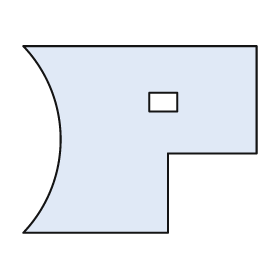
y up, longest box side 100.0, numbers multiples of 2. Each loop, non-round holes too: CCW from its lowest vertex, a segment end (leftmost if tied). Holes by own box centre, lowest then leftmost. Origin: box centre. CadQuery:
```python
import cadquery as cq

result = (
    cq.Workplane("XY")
    .moveTo(-50.0, -40.0)
    .lineTo(12.0, -40.0)
    .lineTo(12.0, -6.0)
    .lineTo(50.0, -6.0)
    .lineTo(50.0, 40.0)
    .lineTo(-50.0, 40.0)
    .threePointArc((-34.0, 0.0), (-50.0, -40.0))
    .close()
    .moveTo(4.0, 12.0)
    .lineTo(16.0, 12.0)
    .lineTo(16.0, 20.0)
    .lineTo(4.0, 20.0)
    .close()
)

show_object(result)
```